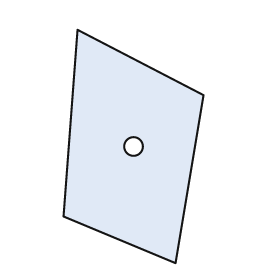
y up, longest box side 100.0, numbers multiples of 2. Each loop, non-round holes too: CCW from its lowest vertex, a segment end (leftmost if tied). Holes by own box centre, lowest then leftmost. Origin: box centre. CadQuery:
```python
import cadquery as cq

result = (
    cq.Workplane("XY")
    .moveTo(18.0, -50.0)
    .lineTo(30.0, 22.0)
    .lineTo(-24.0, 50.0)
    .lineTo(-30.0, -30.0)
    .close()
    .moveTo(0.0, 0.0)
    .circle(4.0)
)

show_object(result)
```